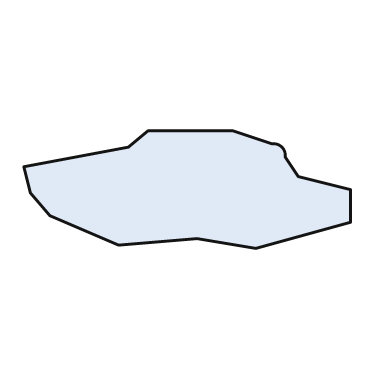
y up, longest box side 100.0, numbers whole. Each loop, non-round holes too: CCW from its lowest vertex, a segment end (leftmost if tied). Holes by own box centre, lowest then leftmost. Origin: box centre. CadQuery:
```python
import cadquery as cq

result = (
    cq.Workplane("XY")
    .moveTo(21.0, -18.0)
    .lineTo(50.0, -10.0)
    .lineTo(50.0, 0.0)
    .lineTo(34.0, 4.0)
    .lineTo(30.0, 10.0)
    .threePointArc((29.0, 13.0), (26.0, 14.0))
    .lineTo(14.0, 18.0)
    .lineTo(-12.0, 18.0)
    .lineTo(-18.0, 13.0)
    .lineTo(-50.0, 7.0)
    .lineTo(-48.0, -1.0)
    .lineTo(-42.0, -8.0)
    .lineTo(-21.0, -17.0)
    .lineTo(3.0, -15.0)
    .close()
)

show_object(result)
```